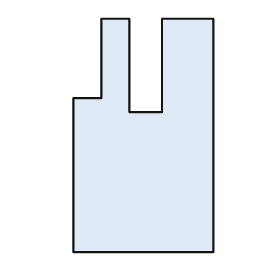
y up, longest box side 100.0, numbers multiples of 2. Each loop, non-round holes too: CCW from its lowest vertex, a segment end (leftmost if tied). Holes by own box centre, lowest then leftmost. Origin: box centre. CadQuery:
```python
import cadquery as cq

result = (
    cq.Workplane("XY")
    .moveTo(-30.0, -50.0)
    .lineTo(30.0, -50.0)
    .lineTo(30.0, 50.0)
    .lineTo(8.0, 50.0)
    .lineTo(8.0, 10.0)
    .lineTo(-6.0, 10.0)
    .lineTo(-6.0, 50.0)
    .lineTo(-18.0, 50.0)
    .lineTo(-18.0, 16.0)
    .lineTo(-30.0, 16.0)
    .close()
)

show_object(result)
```